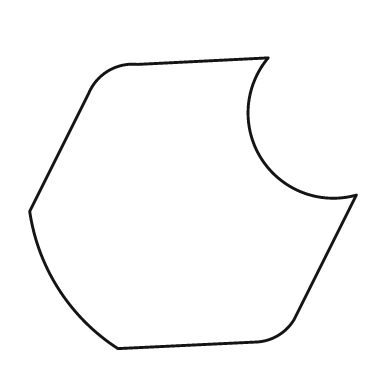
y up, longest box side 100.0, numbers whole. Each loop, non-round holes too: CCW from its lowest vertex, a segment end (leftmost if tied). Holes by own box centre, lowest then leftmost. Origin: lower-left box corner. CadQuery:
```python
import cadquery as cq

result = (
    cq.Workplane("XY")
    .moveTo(27.0, 0.0)
    .lineTo(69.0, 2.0)
    .threePointArc((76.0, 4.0), (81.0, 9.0))
    .lineTo(100.0, 47.0)
    .threePointArc((71.0, 58.0), (73.0, 89.0))
    .lineTo(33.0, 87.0)
    .threePointArc((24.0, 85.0), (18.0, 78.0))
    .lineTo(0.0, 42.0)
    .threePointArc((9.0, 18.0), (27.0, 0.0))
    .close()
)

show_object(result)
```